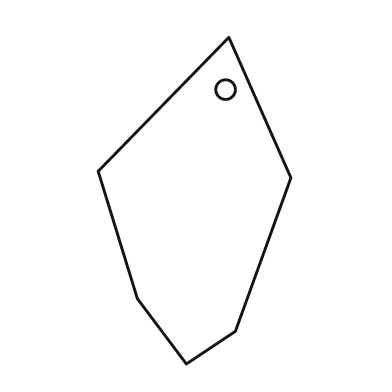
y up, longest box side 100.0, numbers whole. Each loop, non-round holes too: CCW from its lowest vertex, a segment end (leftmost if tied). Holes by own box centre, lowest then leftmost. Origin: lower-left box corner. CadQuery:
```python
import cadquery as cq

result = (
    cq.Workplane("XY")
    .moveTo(27.0, 0.0)
    .lineTo(42.0, 10.0)
    .lineTo(59.0, 57.0)
    .lineTo(40.0, 100.0)
    .lineTo(0.0, 59.0)
    .lineTo(12.0, 20.0)
    .close()
    .moveTo(39.0, 84.0)
    .circle(3.0)
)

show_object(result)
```